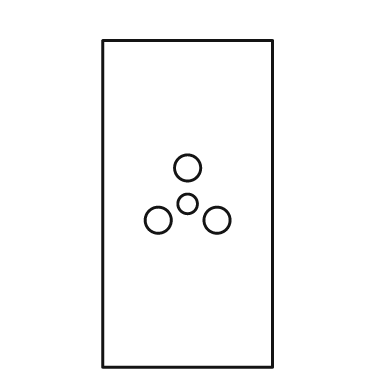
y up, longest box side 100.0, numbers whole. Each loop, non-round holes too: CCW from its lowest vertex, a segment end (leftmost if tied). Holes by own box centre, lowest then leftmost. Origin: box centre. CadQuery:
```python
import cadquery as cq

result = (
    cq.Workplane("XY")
    .moveTo(-26.0, -50.0)
    .lineTo(26.0, -50.0)
    .lineTo(26.0, 50.0)
    .lineTo(-26.0, 50.0)
    .close()
    .moveTo(-9.0, -5.0)
    .circle(4.0)
    .moveTo(9.0, -5.0)
    .circle(4.0)
    .moveTo(0.0, 0.0)
    .circle(3.0)
    .moveTo(0.0, 11.0)
    .circle(4.0)
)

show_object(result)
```